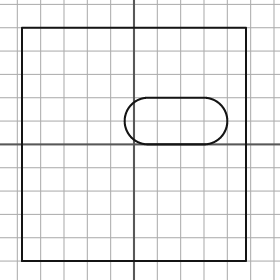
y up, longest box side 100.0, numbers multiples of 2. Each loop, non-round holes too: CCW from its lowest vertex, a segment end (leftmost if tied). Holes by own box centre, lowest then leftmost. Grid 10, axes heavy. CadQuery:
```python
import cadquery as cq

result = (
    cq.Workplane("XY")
    .moveTo(-48.0, -50.0)
    .lineTo(48.0, -50.0)
    .lineTo(48.0, 50.0)
    .lineTo(-48.0, 50.0)
    .close()
    .moveTo(6.0, 0.0)
    .lineTo(30.0, 0.0)
    .threePointArc((40.0, 10.0), (30.0, 20.0))
    .lineTo(6.0, 20.0)
    .threePointArc((-4.0, 10.0), (6.0, 0.0))
    .close()
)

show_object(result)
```